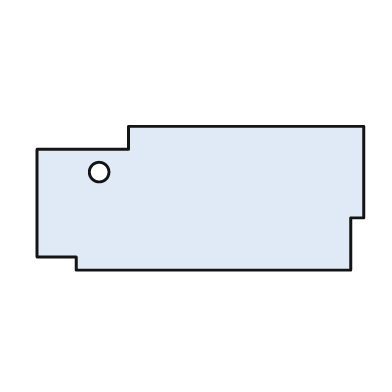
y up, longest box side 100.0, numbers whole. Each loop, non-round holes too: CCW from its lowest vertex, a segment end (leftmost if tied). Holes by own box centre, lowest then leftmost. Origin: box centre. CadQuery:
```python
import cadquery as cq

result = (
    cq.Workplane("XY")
    .moveTo(-38.0, -22.0)
    .lineTo(46.0, -22.0)
    .lineTo(46.0, -6.0)
    .lineTo(50.0, -6.0)
    .lineTo(50.0, 22.0)
    .lineTo(-22.0, 22.0)
    .lineTo(-22.0, 15.0)
    .lineTo(-50.0, 15.0)
    .lineTo(-50.0, -18.0)
    .lineTo(-38.0, -18.0)
    .close()
    .moveTo(-31.0, 8.0)
    .circle(3.0)
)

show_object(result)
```